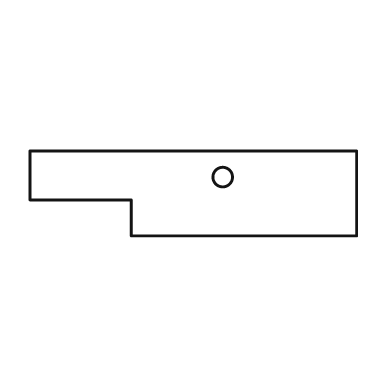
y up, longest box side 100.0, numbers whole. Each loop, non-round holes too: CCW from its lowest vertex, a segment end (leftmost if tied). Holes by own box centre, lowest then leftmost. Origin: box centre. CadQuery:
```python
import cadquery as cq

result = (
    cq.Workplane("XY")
    .moveTo(-19.0, -13.0)
    .lineTo(50.0, -13.0)
    .lineTo(50.0, 13.0)
    .lineTo(-50.0, 13.0)
    .lineTo(-50.0, -2.0)
    .lineTo(-19.0, -2.0)
    .close()
    .moveTo(9.0, 5.0)
    .circle(3.0)
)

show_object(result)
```